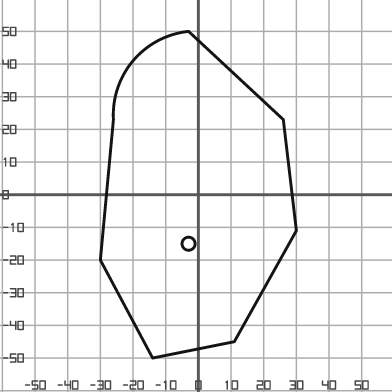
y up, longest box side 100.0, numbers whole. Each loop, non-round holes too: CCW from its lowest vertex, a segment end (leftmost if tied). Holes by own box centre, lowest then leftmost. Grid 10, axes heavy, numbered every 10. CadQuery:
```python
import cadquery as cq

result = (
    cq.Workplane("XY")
    .moveTo(-14.0, -50.0)
    .lineTo(11.0, -45.0)
    .lineTo(30.0, -11.0)
    .lineTo(26.0, 23.0)
    .lineTo(-3.0, 50.0)
    .threePointArc((-20.0, 41.0), (-26.0, 23.0))
    .lineTo(-30.0, -20.0)
    .close()
    .moveTo(-3.0, -15.0)
    .circle(2.0)
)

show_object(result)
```